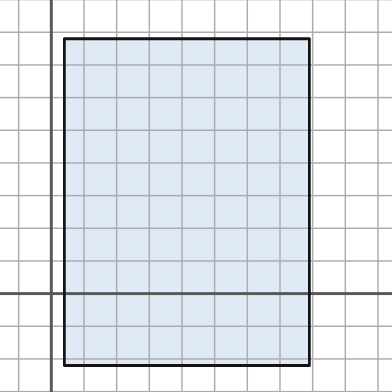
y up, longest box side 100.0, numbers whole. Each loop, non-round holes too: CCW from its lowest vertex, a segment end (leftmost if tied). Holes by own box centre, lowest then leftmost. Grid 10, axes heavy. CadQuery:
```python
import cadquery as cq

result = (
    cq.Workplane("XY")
    .moveTo(4.0, -22.0)
    .lineTo(79.0, -22.0)
    .lineTo(79.0, 78.0)
    .lineTo(4.0, 78.0)
    .close()
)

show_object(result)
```